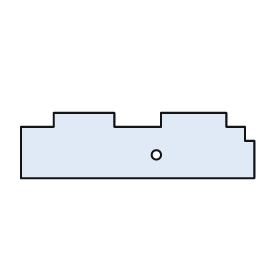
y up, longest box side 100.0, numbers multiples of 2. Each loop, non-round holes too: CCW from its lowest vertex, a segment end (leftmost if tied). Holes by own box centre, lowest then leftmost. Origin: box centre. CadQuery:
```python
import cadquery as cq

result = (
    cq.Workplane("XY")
    .moveTo(-50.0, -14.0)
    .lineTo(50.0, -14.0)
    .lineTo(50.0, 2.0)
    .lineTo(46.0, 2.0)
    .lineTo(46.0, 8.0)
    .lineTo(38.0, 8.0)
    .lineTo(38.0, 14.0)
    .lineTo(10.0, 14.0)
    .lineTo(10.0, 8.0)
    .lineTo(-10.0, 8.0)
    .lineTo(-10.0, 14.0)
    .lineTo(-36.0, 14.0)
    .lineTo(-36.0, 8.0)
    .lineTo(-50.0, 8.0)
    .close()
    .moveTo(8.0, -4.0)
    .circle(2.0)
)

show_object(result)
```